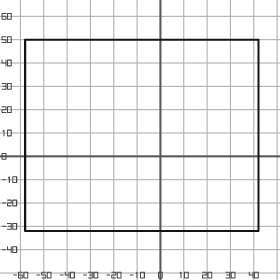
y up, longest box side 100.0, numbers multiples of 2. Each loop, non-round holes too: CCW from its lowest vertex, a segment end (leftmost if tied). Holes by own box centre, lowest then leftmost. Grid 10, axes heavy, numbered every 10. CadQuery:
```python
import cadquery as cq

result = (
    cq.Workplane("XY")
    .moveTo(-58.0, -32.0)
    .lineTo(42.0, -32.0)
    .lineTo(42.0, 50.0)
    .lineTo(-58.0, 50.0)
    .close()
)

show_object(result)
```